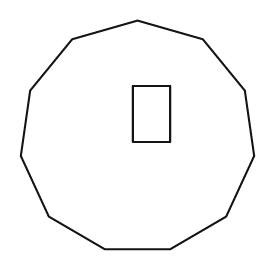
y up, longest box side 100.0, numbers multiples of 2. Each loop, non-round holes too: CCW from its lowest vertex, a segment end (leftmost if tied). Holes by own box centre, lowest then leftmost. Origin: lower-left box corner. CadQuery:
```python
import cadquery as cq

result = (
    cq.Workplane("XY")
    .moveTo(36.0, 0.0)
    .lineTo(64.0, 0.0)
    .lineTo(88.0, 14.0)
    .lineTo(100.0, 40.0)
    .lineTo(96.0, 68.0)
    .lineTo(78.0, 90.0)
    .lineTo(50.0, 98.0)
    .lineTo(22.0, 90.0)
    .lineTo(4.0, 68.0)
    .lineTo(0.0, 40.0)
    .lineTo(12.0, 14.0)
    .close()
    .moveTo(48.0, 46.0)
    .lineTo(64.0, 46.0)
    .lineTo(64.0, 70.0)
    .lineTo(48.0, 70.0)
    .close()
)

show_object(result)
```